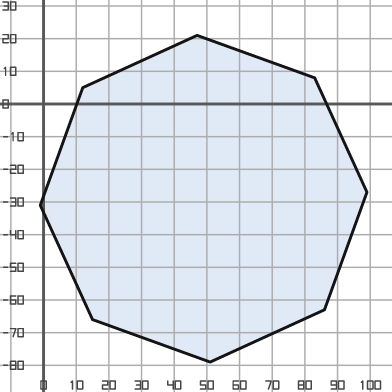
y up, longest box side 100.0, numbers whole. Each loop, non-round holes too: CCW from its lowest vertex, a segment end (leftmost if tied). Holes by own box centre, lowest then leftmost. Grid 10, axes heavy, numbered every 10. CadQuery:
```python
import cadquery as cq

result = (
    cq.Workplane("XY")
    .moveTo(51.0, -79.0)
    .lineTo(86.0, -63.0)
    .lineTo(99.0, -27.0)
    .lineTo(83.0, 8.0)
    .lineTo(47.0, 21.0)
    .lineTo(12.0, 5.0)
    .lineTo(-1.0, -31.0)
    .lineTo(15.0, -66.0)
    .close()
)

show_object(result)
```